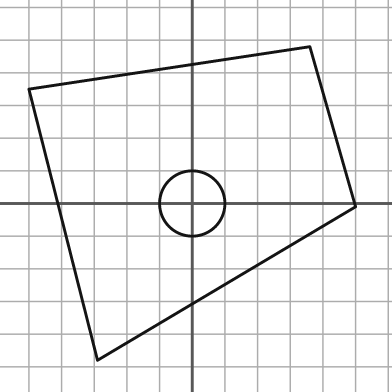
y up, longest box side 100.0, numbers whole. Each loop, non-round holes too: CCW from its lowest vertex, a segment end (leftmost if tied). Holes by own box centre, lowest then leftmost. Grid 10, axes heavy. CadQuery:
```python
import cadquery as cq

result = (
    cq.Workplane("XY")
    .moveTo(-29.0, -48.0)
    .lineTo(50.0, -1.0)
    .lineTo(36.0, 48.0)
    .lineTo(-50.0, 35.0)
    .close()
    .moveTo(0.0, 0.0)
    .circle(10.0)
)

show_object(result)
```